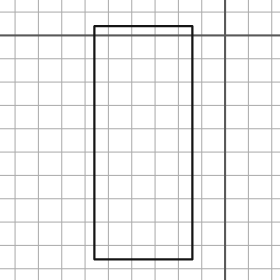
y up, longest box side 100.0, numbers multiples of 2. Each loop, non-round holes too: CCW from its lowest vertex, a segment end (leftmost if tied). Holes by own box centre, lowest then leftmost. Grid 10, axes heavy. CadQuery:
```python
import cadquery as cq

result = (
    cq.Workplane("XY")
    .moveTo(-56.0, -96.0)
    .lineTo(-14.0, -96.0)
    .lineTo(-14.0, 4.0)
    .lineTo(-56.0, 4.0)
    .close()
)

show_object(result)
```